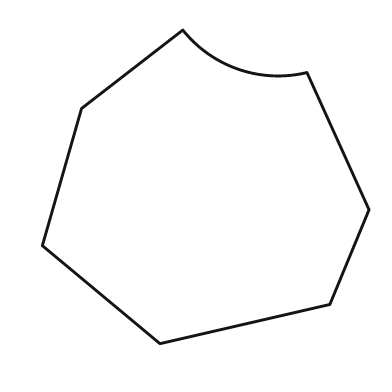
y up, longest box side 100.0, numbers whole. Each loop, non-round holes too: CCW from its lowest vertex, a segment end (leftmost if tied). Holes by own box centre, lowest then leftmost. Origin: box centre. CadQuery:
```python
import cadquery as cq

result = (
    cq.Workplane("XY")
    .moveTo(-14.0, -48.0)
    .lineTo(38.0, -36.0)
    .lineTo(50.0, -7.0)
    .lineTo(31.0, 35.0)
    .threePointArc((10.0, 36.0), (-7.0, 48.0))
    .lineTo(-38.0, 24.0)
    .lineTo(-50.0, -18.0)
    .close()
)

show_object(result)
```